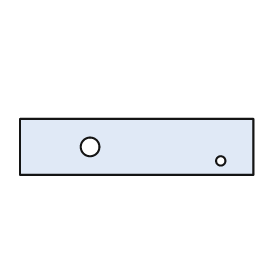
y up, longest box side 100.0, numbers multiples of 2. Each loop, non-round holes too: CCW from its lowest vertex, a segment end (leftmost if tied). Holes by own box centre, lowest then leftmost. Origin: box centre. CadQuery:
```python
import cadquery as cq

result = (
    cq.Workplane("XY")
    .moveTo(-50.0, -12.0)
    .lineTo(50.0, -12.0)
    .lineTo(50.0, 12.0)
    .lineTo(-50.0, 12.0)
    .close()
    .moveTo(36.0, -6.0)
    .circle(2.0)
    .moveTo(-20.0, 0.0)
    .circle(4.0)
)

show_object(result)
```